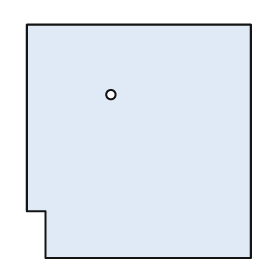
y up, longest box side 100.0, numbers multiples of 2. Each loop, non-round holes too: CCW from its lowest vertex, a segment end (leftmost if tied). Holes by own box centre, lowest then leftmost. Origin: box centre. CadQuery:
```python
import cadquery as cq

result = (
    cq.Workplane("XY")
    .moveTo(-40.0, -50.0)
    .lineTo(48.0, -50.0)
    .lineTo(48.0, 50.0)
    .lineTo(-48.0, 50.0)
    .lineTo(-48.0, -30.0)
    .lineTo(-40.0, -30.0)
    .close()
    .moveTo(-12.0, 20.0)
    .circle(2.0)
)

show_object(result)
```